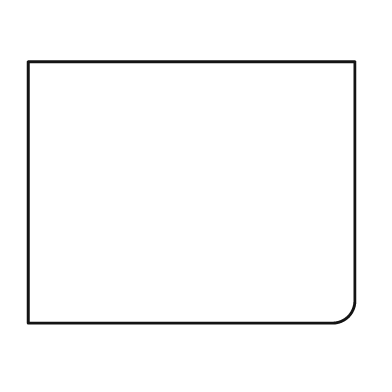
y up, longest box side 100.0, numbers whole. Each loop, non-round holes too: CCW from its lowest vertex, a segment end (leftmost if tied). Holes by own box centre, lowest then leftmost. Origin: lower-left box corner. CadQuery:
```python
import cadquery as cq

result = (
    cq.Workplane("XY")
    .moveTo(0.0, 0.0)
    .lineTo(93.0, 0.0)
    .threePointArc((98.0, 2.0), (100.0, 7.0))
    .lineTo(100.0, 80.0)
    .lineTo(0.0, 80.0)
    .close()
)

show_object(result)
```